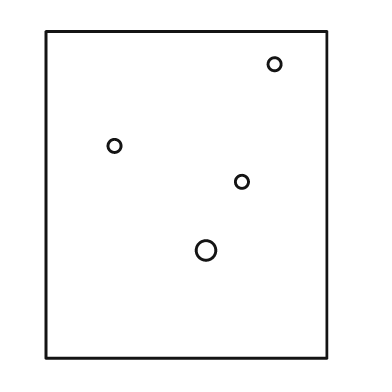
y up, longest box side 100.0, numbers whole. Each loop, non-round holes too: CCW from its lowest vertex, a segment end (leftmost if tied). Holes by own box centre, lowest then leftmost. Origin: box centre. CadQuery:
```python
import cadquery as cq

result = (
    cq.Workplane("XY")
    .moveTo(-43.0, -50.0)
    .lineTo(43.0, -50.0)
    .lineTo(43.0, 50.0)
    .lineTo(-43.0, 50.0)
    .close()
    .moveTo(6.0, -17.0)
    .circle(3.0)
    .moveTo(17.0, 4.0)
    .circle(2.0)
    .moveTo(-22.0, 15.0)
    .circle(2.0)
    .moveTo(27.0, 40.0)
    .circle(2.0)
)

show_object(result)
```